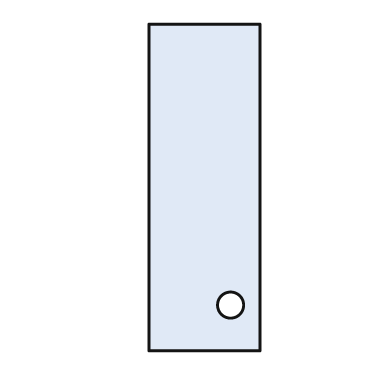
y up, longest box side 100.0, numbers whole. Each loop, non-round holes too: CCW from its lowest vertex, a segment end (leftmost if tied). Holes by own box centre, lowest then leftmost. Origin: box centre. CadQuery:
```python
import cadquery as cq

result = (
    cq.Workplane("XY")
    .moveTo(-17.0, -50.0)
    .lineTo(17.0, -50.0)
    .lineTo(17.0, 50.0)
    .lineTo(-17.0, 50.0)
    .close()
    .moveTo(8.0, -36.0)
    .circle(4.0)
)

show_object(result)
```